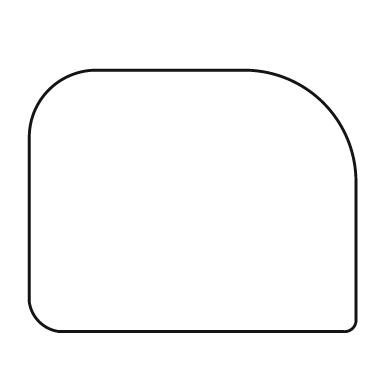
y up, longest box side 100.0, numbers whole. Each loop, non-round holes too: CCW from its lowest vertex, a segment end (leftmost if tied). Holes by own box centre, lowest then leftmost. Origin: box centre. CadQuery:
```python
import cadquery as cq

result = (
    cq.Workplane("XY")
    .moveTo(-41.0, -40.0)
    .lineTo(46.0, -40.0)
    .threePointArc((49.0, -39.0), (50.0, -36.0))
    .lineTo(50.0, 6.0)
    .threePointArc((40.0, 30.0), (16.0, 40.0))
    .lineTo(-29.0, 40.0)
    .threePointArc((-44.0, 34.0), (-50.0, 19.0))
    .lineTo(-50.0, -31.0)
    .threePointArc((-47.0, -37.0), (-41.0, -40.0))
    .close()
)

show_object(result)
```